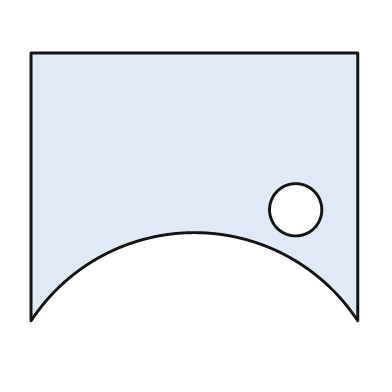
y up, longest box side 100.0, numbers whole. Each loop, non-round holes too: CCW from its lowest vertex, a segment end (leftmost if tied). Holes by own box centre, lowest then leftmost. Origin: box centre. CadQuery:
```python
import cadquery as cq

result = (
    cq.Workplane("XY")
    .moveTo(-50.0, -41.0)
    .threePointArc((0.0, -14.0), (50.0, -41.0))
    .lineTo(50.0, 41.0)
    .lineTo(-50.0, 41.0)
    .close()
    .moveTo(31.0, -7.0)
    .circle(8.0)
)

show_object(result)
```